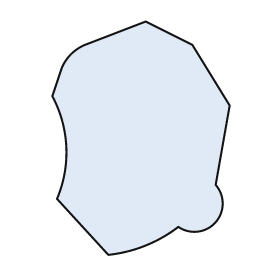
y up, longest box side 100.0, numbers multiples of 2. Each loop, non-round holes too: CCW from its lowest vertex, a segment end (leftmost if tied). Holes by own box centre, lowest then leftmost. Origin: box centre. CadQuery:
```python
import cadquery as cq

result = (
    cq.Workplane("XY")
    .moveTo(-14.0, -50.0)
    .threePointArc((2.0, -46.0), (16.0, -38.0))
    .threePointArc((32.0, -36.0), (32.0, -20.0))
    .lineTo(38.0, 14.0)
    .lineTo(22.0, 40.0)
    .lineTo(2.0, 50.0)
    .lineTo(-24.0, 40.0)
    .threePointArc((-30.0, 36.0), (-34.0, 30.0))
    .lineTo(-38.0, 18.0)
    .threePointArc((-32.0, -4.0), (-36.0, -26.0))
    .close()
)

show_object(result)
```